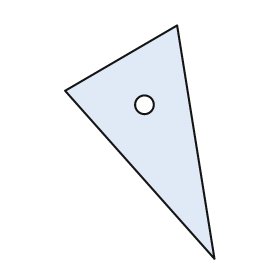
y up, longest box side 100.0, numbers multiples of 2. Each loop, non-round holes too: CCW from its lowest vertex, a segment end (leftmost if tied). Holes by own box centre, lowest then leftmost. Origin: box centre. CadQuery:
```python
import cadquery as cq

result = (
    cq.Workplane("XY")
    .moveTo(32.0, -50.0)
    .lineTo(16.0, 50.0)
    .lineTo(-32.0, 22.0)
    .close()
    .moveTo(2.0, 16.0)
    .circle(4.0)
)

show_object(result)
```